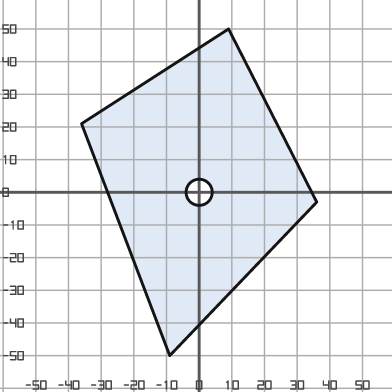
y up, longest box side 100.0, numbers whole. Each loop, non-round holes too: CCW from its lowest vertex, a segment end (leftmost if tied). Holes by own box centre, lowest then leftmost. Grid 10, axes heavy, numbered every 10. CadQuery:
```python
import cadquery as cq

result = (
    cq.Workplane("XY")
    .moveTo(-9.0, -50.0)
    .lineTo(36.0, -3.0)
    .lineTo(9.0, 50.0)
    .lineTo(-36.0, 21.0)
    .close()
    .moveTo(0.0, 0.0)
    .circle(4.0)
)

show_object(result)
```